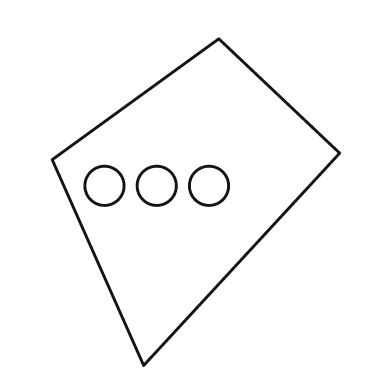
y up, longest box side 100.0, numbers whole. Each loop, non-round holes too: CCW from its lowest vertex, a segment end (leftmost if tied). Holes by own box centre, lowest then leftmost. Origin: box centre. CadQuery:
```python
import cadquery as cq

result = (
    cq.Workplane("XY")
    .moveTo(-16.0, -50.0)
    .lineTo(44.0, 15.0)
    .lineTo(7.0, 50.0)
    .lineTo(-44.0, 13.0)
    .close()
    .moveTo(-28.0, 5.0)
    .circle(6.0)
    .moveTo(-12.0, 5.0)
    .circle(6.0)
    .moveTo(4.0, 5.0)
    .circle(6.0)
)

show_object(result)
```